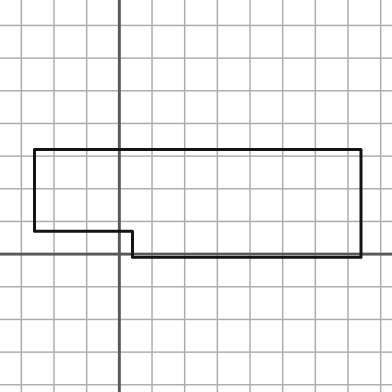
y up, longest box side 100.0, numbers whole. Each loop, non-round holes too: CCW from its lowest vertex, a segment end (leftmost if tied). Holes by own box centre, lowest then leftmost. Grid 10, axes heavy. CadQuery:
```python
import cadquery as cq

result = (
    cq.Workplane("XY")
    .moveTo(4.0, -1.0)
    .lineTo(74.0, -1.0)
    .lineTo(74.0, 32.0)
    .lineTo(-26.0, 32.0)
    .lineTo(-26.0, 7.0)
    .lineTo(4.0, 7.0)
    .close()
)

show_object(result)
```